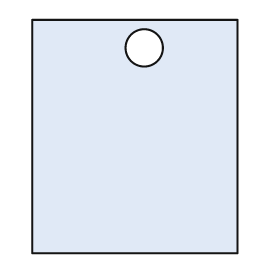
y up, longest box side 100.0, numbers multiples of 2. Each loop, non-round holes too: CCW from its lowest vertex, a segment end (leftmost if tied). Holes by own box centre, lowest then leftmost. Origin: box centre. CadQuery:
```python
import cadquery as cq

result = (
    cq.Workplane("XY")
    .moveTo(-44.0, -50.0)
    .lineTo(44.0, -50.0)
    .lineTo(44.0, 50.0)
    .lineTo(-44.0, 50.0)
    .close()
    .moveTo(4.0, 38.0)
    .circle(8.0)
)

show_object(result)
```